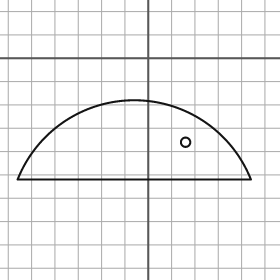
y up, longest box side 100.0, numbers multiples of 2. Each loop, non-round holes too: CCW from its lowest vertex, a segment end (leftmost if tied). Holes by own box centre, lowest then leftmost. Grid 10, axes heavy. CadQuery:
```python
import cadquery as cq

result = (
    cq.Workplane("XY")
    .moveTo(-56.0, -52.0)
    .lineTo(44.0, -52.0)
    .threePointArc((-6.0, -18.0), (-56.0, -52.0))
    .close()
    .moveTo(16.0, -36.0)
    .circle(2.0)
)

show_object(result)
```